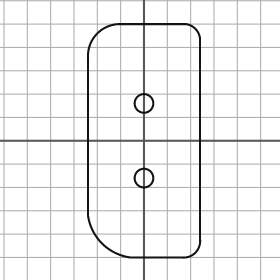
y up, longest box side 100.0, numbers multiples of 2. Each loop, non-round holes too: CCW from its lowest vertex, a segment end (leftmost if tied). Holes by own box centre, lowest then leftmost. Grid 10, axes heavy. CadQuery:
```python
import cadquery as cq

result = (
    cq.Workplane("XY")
    .moveTo(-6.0, -50.0)
    .lineTo(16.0, -50.0)
    .threePointArc((22.0, -48.0), (24.0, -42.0))
    .lineTo(24.0, 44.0)
    .threePointArc((22.0, 48.0), (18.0, 50.0))
    .lineTo(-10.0, 50.0)
    .threePointArc((-20.0, 46.0), (-24.0, 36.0))
    .lineTo(-24.0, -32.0)
    .threePointArc((-18.0, -44.0), (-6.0, -50.0))
    .close()
    .moveTo(0.0, -16.0)
    .circle(4.0)
    .moveTo(0.0, 16.0)
    .circle(4.0)
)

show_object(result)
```